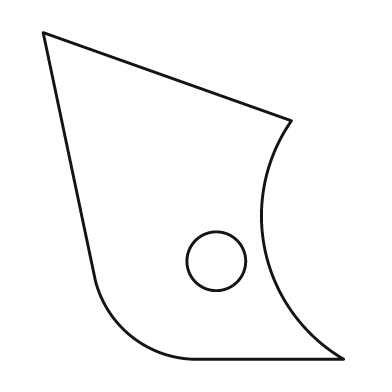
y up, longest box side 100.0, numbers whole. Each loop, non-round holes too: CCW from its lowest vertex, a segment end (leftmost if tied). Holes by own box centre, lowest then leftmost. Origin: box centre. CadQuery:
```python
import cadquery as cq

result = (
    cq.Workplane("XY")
    .moveTo(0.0, -50.0)
    .lineTo(46.0, -50.0)
    .threePointArc((22.0, -17.0), (30.0, 23.0))
    .lineTo(-46.0, 50.0)
    .lineTo(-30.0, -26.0)
    .threePointArc((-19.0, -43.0), (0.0, -50.0))
    .close()
    .moveTo(7.0, -20.0)
    .circle(9.0)
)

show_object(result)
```